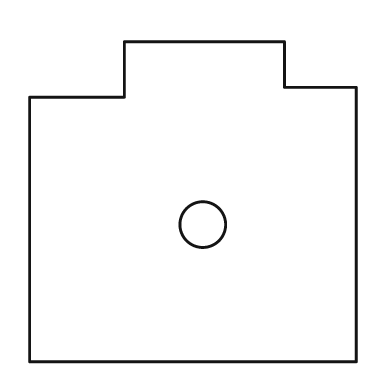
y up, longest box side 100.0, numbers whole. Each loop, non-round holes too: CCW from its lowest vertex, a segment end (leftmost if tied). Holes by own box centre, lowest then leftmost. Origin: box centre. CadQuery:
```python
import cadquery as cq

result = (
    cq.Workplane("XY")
    .moveTo(-50.0, -49.0)
    .lineTo(50.0, -49.0)
    .lineTo(50.0, 35.0)
    .lineTo(28.0, 35.0)
    .lineTo(28.0, 49.0)
    .lineTo(-21.0, 49.0)
    .lineTo(-21.0, 32.0)
    .lineTo(-50.0, 32.0)
    .close()
    .moveTo(3.0, -7.0)
    .circle(7.0)
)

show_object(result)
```